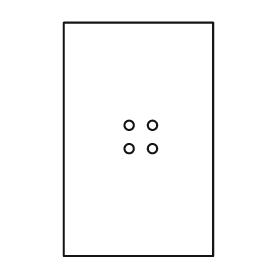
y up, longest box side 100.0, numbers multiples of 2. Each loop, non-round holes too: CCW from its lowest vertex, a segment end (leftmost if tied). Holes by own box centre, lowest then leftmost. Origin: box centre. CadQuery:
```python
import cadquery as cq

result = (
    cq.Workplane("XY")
    .moveTo(-32.0, -50.0)
    .lineTo(32.0, -50.0)
    .lineTo(32.0, 50.0)
    .lineTo(-32.0, 50.0)
    .close()
    .moveTo(-4.0, -4.0)
    .circle(2.0)
    .moveTo(6.0, -4.0)
    .circle(2.0)
    .moveTo(-4.0, 6.0)
    .circle(2.0)
    .moveTo(6.0, 6.0)
    .circle(2.0)
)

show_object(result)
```